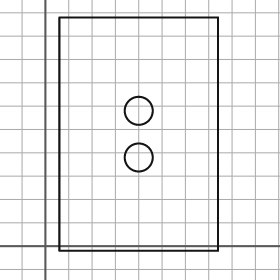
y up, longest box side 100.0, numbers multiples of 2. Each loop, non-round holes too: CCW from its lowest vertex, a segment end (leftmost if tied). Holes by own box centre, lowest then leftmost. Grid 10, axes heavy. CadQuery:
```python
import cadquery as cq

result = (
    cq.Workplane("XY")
    .moveTo(6.0, -2.0)
    .lineTo(74.0, -2.0)
    .lineTo(74.0, 98.0)
    .lineTo(6.0, 98.0)
    .close()
    .moveTo(40.0, 38.0)
    .circle(6.0)
    .moveTo(40.0, 58.0)
    .circle(6.0)
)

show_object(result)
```